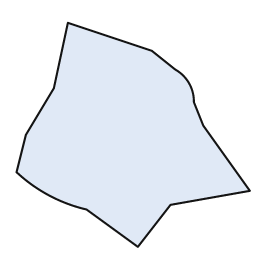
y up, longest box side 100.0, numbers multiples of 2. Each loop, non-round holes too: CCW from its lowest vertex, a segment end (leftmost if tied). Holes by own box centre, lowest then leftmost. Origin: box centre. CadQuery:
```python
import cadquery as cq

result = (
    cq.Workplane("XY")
    .moveTo(2.0, -48.0)
    .lineTo(16.0, -30.0)
    .lineTo(50.0, -24.0)
    .lineTo(30.0, 4.0)
    .lineTo(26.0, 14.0)
    .threePointArc((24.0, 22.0), (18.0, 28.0))
    .lineTo(8.0, 36.0)
    .lineTo(-28.0, 48.0)
    .lineTo(-34.0, 20.0)
    .lineTo(-46.0, 0.0)
    .lineTo(-50.0, -16.0)
    .threePointArc((-36.0, -26.0), (-20.0, -32.0))
    .close()
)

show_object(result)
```